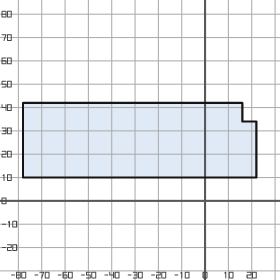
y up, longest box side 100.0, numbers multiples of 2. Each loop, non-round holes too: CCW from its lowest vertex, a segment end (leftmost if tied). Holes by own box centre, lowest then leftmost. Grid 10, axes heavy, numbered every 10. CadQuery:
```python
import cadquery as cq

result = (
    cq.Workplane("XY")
    .moveTo(-78.0, 10.0)
    .lineTo(22.0, 10.0)
    .lineTo(22.0, 34.0)
    .lineTo(16.0, 34.0)
    .lineTo(16.0, 42.0)
    .lineTo(-78.0, 42.0)
    .close()
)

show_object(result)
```